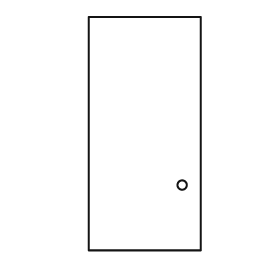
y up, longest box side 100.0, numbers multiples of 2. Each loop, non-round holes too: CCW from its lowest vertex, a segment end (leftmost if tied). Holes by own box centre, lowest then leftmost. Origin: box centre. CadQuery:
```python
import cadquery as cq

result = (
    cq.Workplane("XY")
    .moveTo(-24.0, -50.0)
    .lineTo(24.0, -50.0)
    .lineTo(24.0, 50.0)
    .lineTo(-24.0, 50.0)
    .close()
    .moveTo(16.0, -22.0)
    .circle(2.0)
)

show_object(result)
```